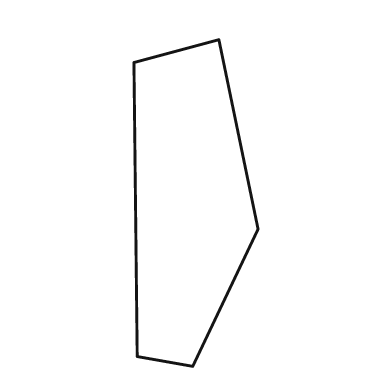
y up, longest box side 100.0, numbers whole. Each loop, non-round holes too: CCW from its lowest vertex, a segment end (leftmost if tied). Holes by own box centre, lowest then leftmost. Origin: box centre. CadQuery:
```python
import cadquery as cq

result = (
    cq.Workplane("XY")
    .moveTo(-1.0, -50.0)
    .lineTo(19.0, -8.0)
    .lineTo(7.0, 50.0)
    .lineTo(-19.0, 43.0)
    .lineTo(-18.0, -47.0)
    .close()
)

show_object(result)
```